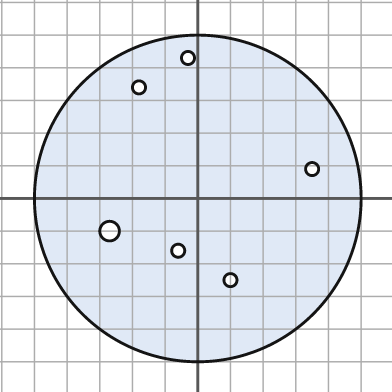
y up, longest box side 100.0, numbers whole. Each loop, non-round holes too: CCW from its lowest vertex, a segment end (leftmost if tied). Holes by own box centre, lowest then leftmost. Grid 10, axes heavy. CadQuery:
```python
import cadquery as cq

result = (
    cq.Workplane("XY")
    .moveTo(0.0, 0.0)
    .circle(50.0)
    .moveTo(10.0, -25.0)
    .circle(2.0)
    .moveTo(-6.0, -16.0)
    .circle(2.0)
    .moveTo(-27.0, -10.0)
    .circle(3.0)
    .moveTo(35.0, 9.0)
    .circle(2.0)
    .moveTo(-18.0, 34.0)
    .circle(2.0)
    .moveTo(-3.0, 43.0)
    .circle(2.0)
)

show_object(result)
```